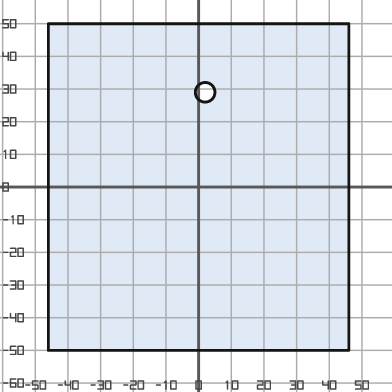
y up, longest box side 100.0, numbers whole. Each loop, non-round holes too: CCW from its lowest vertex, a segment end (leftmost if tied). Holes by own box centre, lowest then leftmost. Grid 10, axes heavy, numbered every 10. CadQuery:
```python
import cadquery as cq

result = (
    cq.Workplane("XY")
    .moveTo(-46.0, -50.0)
    .lineTo(46.0, -50.0)
    .lineTo(46.0, 50.0)
    .lineTo(-46.0, 50.0)
    .close()
    .moveTo(2.0, 29.0)
    .circle(3.0)
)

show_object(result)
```